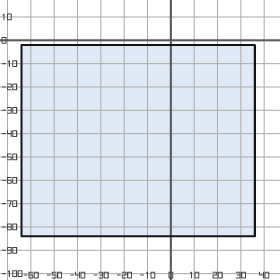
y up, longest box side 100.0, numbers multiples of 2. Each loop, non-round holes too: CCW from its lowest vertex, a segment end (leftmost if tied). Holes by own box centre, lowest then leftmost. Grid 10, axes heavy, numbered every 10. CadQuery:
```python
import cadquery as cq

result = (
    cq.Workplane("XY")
    .moveTo(-64.0, -84.0)
    .lineTo(36.0, -84.0)
    .lineTo(36.0, -2.0)
    .lineTo(-64.0, -2.0)
    .close()
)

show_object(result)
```